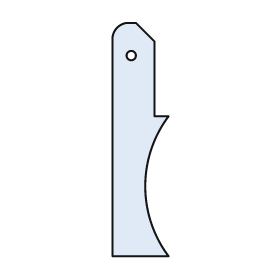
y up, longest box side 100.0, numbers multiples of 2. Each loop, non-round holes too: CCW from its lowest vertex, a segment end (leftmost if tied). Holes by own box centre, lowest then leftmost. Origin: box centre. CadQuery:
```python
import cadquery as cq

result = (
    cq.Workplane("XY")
    .moveTo(-12.0, -50.0)
    .lineTo(12.0, -50.0)
    .threePointArc((2.0, -20.0), (12.0, 10.0))
    .lineTo(6.0, 10.0)
    .lineTo(6.0, 42.0)
    .lineTo(-2.0, 50.0)
    .lineTo(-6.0, 50.0)
    .threePointArc((-10.0, 48.0), (-12.0, 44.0))
    .close()
    .moveTo(-4.0, 36.0)
    .circle(2.0)
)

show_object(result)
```